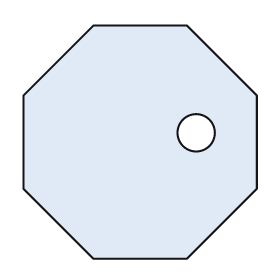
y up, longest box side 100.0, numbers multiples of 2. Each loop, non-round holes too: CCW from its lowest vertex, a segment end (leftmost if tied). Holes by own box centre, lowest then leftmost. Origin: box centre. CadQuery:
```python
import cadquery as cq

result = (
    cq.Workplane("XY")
    .moveTo(-20.0, -50.0)
    .lineTo(20.0, -50.0)
    .lineTo(50.0, -20.0)
    .lineTo(50.0, 20.0)
    .lineTo(20.0, 50.0)
    .lineTo(-20.0, 50.0)
    .lineTo(-50.0, 20.0)
    .lineTo(-50.0, -20.0)
    .close()
    .moveTo(24.0, 4.0)
    .circle(8.0)
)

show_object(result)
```